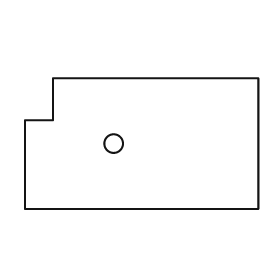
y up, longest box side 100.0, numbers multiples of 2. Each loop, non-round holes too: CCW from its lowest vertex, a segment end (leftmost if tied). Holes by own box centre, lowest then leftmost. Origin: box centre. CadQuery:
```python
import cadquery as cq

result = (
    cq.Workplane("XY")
    .moveTo(-50.0, -28.0)
    .lineTo(50.0, -28.0)
    .lineTo(50.0, 28.0)
    .lineTo(-38.0, 28.0)
    .lineTo(-38.0, 10.0)
    .lineTo(-50.0, 10.0)
    .close()
    .moveTo(-12.0, 0.0)
    .circle(4.0)
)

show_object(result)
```